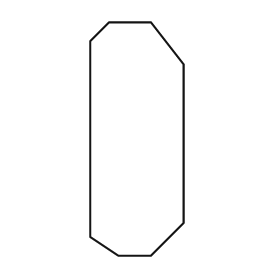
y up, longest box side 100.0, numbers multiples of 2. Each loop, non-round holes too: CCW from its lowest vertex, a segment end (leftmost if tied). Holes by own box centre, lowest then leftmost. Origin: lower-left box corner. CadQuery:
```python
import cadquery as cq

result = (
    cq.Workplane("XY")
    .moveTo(12.0, 0.0)
    .lineTo(26.0, 0.0)
    .lineTo(40.0, 14.0)
    .lineTo(40.0, 82.0)
    .lineTo(26.0, 100.0)
    .lineTo(8.0, 100.0)
    .lineTo(0.0, 92.0)
    .lineTo(0.0, 8.0)
    .close()
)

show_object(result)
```